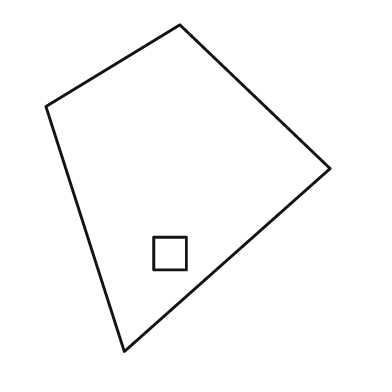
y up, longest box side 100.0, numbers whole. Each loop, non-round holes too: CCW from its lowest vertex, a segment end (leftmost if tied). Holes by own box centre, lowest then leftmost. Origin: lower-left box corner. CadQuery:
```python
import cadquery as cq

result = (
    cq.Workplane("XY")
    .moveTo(24.0, 0.0)
    .lineTo(87.0, 56.0)
    .lineTo(41.0, 100.0)
    .lineTo(0.0, 75.0)
    .close()
    .moveTo(33.0, 25.0)
    .lineTo(43.0, 25.0)
    .lineTo(43.0, 35.0)
    .lineTo(33.0, 35.0)
    .close()
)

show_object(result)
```